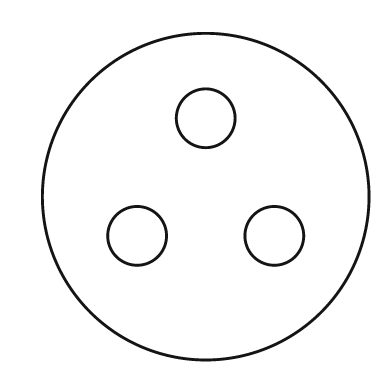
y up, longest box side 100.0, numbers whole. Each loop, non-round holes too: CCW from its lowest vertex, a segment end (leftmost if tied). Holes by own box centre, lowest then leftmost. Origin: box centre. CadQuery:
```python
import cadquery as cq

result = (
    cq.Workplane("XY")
    .moveTo(0.0, 0.0)
    .circle(50.0)
    .moveTo(-21.0, -12.0)
    .circle(9.0)
    .moveTo(21.0, -12.0)
    .circle(9.0)
    .moveTo(0.0, 24.0)
    .circle(9.0)
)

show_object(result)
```